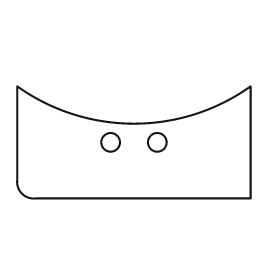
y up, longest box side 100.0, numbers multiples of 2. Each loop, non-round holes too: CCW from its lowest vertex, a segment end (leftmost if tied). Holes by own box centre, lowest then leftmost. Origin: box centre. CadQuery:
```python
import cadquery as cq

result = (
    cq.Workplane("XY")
    .moveTo(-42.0, -24.0)
    .lineTo(50.0, -24.0)
    .lineTo(50.0, 24.0)
    .threePointArc((0.0, 8.0), (-50.0, 24.0))
    .lineTo(-50.0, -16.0)
    .threePointArc((-48.0, -22.0), (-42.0, -24.0))
    .close()
    .moveTo(-10.0, 0.0)
    .circle(4.0)
    .moveTo(10.0, 0.0)
    .circle(4.0)
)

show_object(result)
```